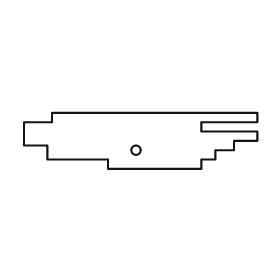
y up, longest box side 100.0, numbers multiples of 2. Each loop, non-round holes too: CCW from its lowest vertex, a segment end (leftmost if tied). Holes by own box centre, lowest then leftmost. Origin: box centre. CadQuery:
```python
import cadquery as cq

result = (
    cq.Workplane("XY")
    .moveTo(-14.0, -12.0)
    .lineTo(26.0, -12.0)
    .lineTo(26.0, -8.0)
    .lineTo(32.0, -8.0)
    .lineTo(32.0, -4.0)
    .lineTo(40.0, -4.0)
    .lineTo(40.0, 0.0)
    .lineTo(50.0, 0.0)
    .lineTo(50.0, 4.0)
    .lineTo(26.0, 4.0)
    .lineTo(26.0, 8.0)
    .lineTo(50.0, 8.0)
    .lineTo(50.0, 12.0)
    .lineTo(-38.0, 12.0)
    .lineTo(-38.0, 8.0)
    .lineTo(-50.0, 8.0)
    .lineTo(-50.0, -2.0)
    .lineTo(-40.0, -2.0)
    .lineTo(-40.0, -8.0)
    .lineTo(-14.0, -8.0)
    .close()
    .moveTo(-2.0, -4.0)
    .circle(2.0)
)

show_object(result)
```